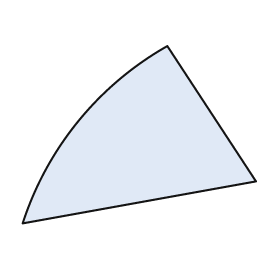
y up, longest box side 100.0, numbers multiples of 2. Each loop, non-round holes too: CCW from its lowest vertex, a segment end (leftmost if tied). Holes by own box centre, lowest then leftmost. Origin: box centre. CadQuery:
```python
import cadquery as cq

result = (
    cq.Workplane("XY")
    .moveTo(-50.0, -38.0)
    .lineTo(50.0, -20.0)
    .lineTo(12.0, 38.0)
    .threePointArc((-26.0, 6.0), (-50.0, -38.0))
    .close()
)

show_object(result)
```